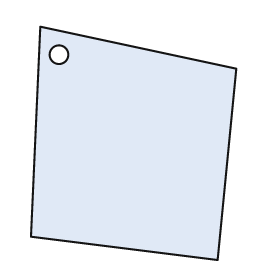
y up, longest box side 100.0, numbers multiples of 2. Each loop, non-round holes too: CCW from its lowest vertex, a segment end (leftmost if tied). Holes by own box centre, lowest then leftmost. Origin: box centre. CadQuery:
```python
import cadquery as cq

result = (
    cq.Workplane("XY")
    .moveTo(36.0, -50.0)
    .lineTo(44.0, 32.0)
    .lineTo(-40.0, 50.0)
    .lineTo(-44.0, -40.0)
    .close()
    .moveTo(-32.0, 38.0)
    .circle(4.0)
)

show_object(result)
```